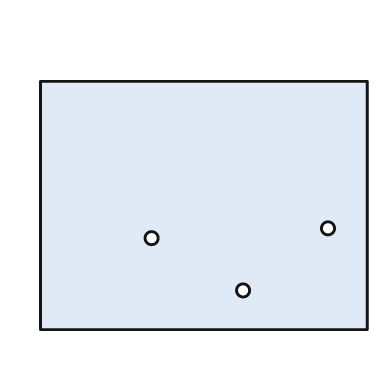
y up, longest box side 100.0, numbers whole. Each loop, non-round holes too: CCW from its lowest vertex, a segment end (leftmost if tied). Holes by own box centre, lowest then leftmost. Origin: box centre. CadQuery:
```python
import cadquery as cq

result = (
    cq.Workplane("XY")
    .moveTo(-50.0, -38.0)
    .lineTo(50.0, -38.0)
    .lineTo(50.0, 38.0)
    .lineTo(-50.0, 38.0)
    .close()
    .moveTo(12.0, -26.0)
    .circle(2.0)
    .moveTo(-16.0, -10.0)
    .circle(2.0)
    .moveTo(38.0, -7.0)
    .circle(2.0)
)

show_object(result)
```